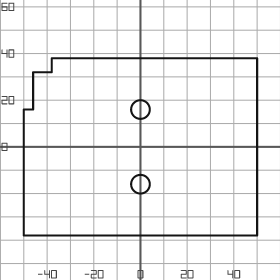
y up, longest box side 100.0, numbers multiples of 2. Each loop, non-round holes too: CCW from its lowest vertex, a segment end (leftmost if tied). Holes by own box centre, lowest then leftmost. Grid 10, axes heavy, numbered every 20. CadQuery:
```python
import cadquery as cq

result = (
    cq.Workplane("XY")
    .moveTo(-50.0, -38.0)
    .lineTo(50.0, -38.0)
    .lineTo(50.0, 38.0)
    .lineTo(-38.0, 38.0)
    .lineTo(-38.0, 32.0)
    .lineTo(-46.0, 32.0)
    .lineTo(-46.0, 16.0)
    .lineTo(-50.0, 16.0)
    .close()
    .moveTo(0.0, -16.0)
    .circle(4.0)
    .moveTo(0.0, 16.0)
    .circle(4.0)
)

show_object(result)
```